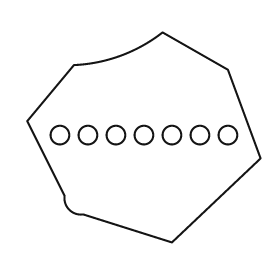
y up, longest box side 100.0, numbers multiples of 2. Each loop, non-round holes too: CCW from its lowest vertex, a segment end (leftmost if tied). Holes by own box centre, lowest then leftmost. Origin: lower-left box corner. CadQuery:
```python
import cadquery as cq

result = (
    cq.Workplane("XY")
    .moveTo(62.0, 0.0)
    .lineTo(100.0, 36.0)
    .lineTo(86.0, 74.0)
    .lineTo(58.0, 90.0)
    .threePointArc((40.0, 80.0), (20.0, 76.0))
    .lineTo(0.0, 52.0)
    .lineTo(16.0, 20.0)
    .threePointArc((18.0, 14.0), (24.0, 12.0))
    .close()
    .moveTo(14.0, 46.0)
    .circle(4.0)
    .moveTo(26.0, 46.0)
    .circle(4.0)
    .moveTo(38.0, 46.0)
    .circle(4.0)
    .moveTo(50.0, 46.0)
    .circle(4.0)
    .moveTo(62.0, 46.0)
    .circle(4.0)
    .moveTo(74.0, 46.0)
    .circle(4.0)
    .moveTo(86.0, 46.0)
    .circle(4.0)
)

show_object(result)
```